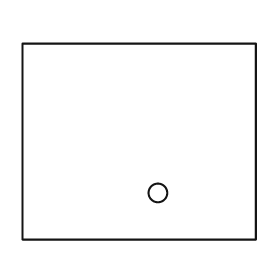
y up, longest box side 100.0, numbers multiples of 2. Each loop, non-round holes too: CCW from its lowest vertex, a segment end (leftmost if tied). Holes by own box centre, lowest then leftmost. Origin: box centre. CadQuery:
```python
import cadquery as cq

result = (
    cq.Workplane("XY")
    .moveTo(-50.0, -42.0)
    .lineTo(50.0, -42.0)
    .lineTo(50.0, 42.0)
    .lineTo(-50.0, 42.0)
    .close()
    .moveTo(8.0, -22.0)
    .circle(4.0)
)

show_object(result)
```